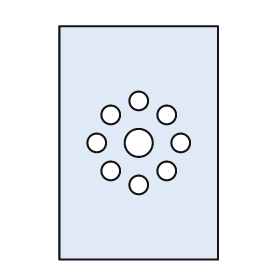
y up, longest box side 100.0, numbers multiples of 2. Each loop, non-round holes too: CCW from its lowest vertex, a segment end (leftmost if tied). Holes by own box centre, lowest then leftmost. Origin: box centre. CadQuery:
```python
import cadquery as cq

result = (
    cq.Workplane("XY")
    .moveTo(-34.0, -50.0)
    .lineTo(34.0, -50.0)
    .lineTo(34.0, 50.0)
    .lineTo(-34.0, 50.0)
    .close()
    .moveTo(0.0, -18.0)
    .circle(4.0)
    .moveTo(-12.0, -12.0)
    .circle(4.0)
    .moveTo(12.0, -12.0)
    .circle(4.0)
    .moveTo(-18.0, 0.0)
    .circle(4.0)
    .moveTo(0.0, 0.0)
    .circle(6.0)
    .moveTo(18.0, 0.0)
    .circle(4.0)
    .moveTo(-12.0, 12.0)
    .circle(4.0)
    .moveTo(12.0, 12.0)
    .circle(4.0)
    .moveTo(0.0, 18.0)
    .circle(4.0)
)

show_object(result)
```